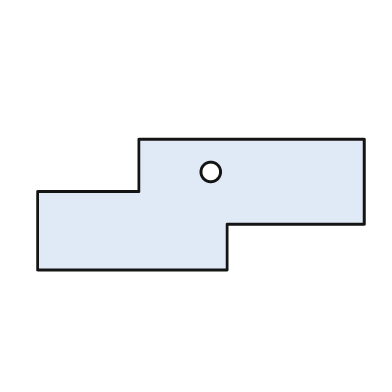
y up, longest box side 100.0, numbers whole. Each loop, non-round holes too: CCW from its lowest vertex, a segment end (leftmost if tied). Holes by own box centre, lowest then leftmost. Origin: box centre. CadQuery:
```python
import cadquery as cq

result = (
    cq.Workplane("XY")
    .moveTo(-50.0, -20.0)
    .lineTo(8.0, -20.0)
    .lineTo(8.0, -6.0)
    .lineTo(50.0, -6.0)
    .lineTo(50.0, 20.0)
    .lineTo(-19.0, 20.0)
    .lineTo(-19.0, 4.0)
    .lineTo(-50.0, 4.0)
    .close()
    .moveTo(3.0, 10.0)
    .circle(3.0)
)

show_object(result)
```